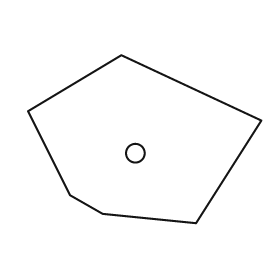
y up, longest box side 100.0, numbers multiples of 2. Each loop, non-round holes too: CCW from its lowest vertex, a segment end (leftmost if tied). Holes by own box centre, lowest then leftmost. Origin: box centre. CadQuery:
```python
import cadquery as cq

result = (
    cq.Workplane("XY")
    .moveTo(22.0, -36.0)
    .lineTo(50.0, 8.0)
    .lineTo(-10.0, 36.0)
    .lineTo(-50.0, 12.0)
    .lineTo(-32.0, -24.0)
    .lineTo(-18.0, -32.0)
    .close()
    .moveTo(-4.0, -6.0)
    .circle(4.0)
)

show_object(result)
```